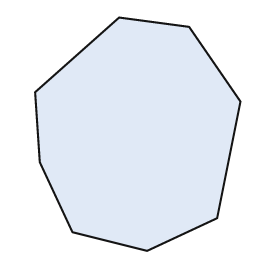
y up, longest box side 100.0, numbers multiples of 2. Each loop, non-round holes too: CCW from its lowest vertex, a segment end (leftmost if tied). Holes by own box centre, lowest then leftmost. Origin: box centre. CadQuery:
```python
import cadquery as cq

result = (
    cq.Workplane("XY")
    .moveTo(4.0, -50.0)
    .lineTo(34.0, -36.0)
    .lineTo(44.0, 14.0)
    .lineTo(22.0, 46.0)
    .lineTo(-8.0, 50.0)
    .lineTo(-44.0, 18.0)
    .lineTo(-42.0, -12.0)
    .lineTo(-28.0, -42.0)
    .close()
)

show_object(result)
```